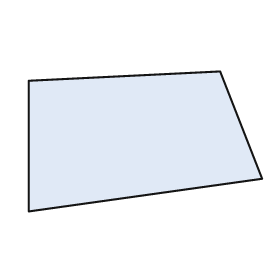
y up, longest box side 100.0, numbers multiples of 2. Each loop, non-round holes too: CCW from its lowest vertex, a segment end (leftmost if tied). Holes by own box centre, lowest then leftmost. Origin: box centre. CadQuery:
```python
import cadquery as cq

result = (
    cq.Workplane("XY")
    .moveTo(-50.0, -30.0)
    .lineTo(50.0, -16.0)
    .lineTo(32.0, 30.0)
    .lineTo(-50.0, 26.0)
    .close()
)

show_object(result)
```